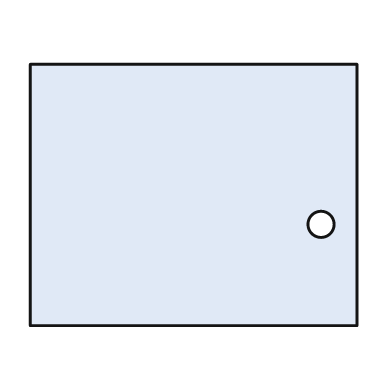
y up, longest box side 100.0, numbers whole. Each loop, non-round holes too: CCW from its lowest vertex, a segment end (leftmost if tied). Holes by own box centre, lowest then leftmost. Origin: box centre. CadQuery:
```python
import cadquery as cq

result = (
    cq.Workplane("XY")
    .moveTo(-50.0, -40.0)
    .lineTo(50.0, -40.0)
    .lineTo(50.0, 40.0)
    .lineTo(-50.0, 40.0)
    .close()
    .moveTo(39.0, -9.0)
    .circle(4.0)
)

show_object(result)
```